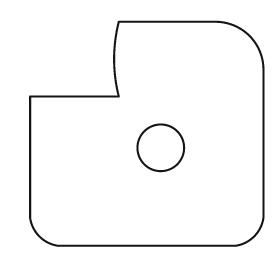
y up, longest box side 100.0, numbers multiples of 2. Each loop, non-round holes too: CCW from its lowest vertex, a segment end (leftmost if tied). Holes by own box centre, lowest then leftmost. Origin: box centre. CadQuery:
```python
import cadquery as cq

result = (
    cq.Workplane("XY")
    .moveTo(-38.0, -48.0)
    .lineTo(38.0, -48.0)
    .threePointArc((46.0, -44.0), (50.0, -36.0))
    .lineTo(50.0, 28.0)
    .threePointArc((44.0, 42.0), (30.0, 48.0))
    .lineTo(-12.0, 48.0)
    .threePointArc((-14.0, 32.0), (-12.0, 16.0))
    .lineTo(-50.0, 16.0)
    .lineTo(-50.0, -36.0)
    .threePointArc((-46.0, -44.0), (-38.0, -48.0))
    .close()
    .moveTo(6.0, -6.0)
    .circle(10.0)
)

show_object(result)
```